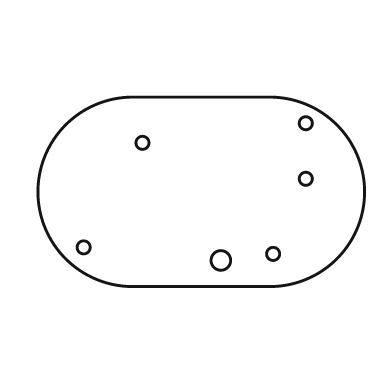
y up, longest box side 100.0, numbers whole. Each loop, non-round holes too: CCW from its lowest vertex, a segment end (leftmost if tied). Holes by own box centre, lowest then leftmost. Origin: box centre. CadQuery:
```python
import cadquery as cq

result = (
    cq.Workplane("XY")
    .moveTo(-21.0, -29.0)
    .lineTo(21.0, -29.0)
    .threePointArc((50.0, 0.0), (21.0, 29.0))
    .lineTo(-21.0, 29.0)
    .threePointArc((-50.0, 0.0), (-21.0, -29.0))
    .close()
    .moveTo(6.0, -21.0)
    .circle(3.0)
    .moveTo(22.0, -19.0)
    .circle(2.0)
    .moveTo(-36.0, -17.0)
    .circle(2.0)
    .moveTo(32.0, 4.0)
    .circle(2.0)
    .moveTo(-18.0, 15.0)
    .circle(2.0)
    .moveTo(32.0, 21.0)
    .circle(2.0)
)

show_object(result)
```